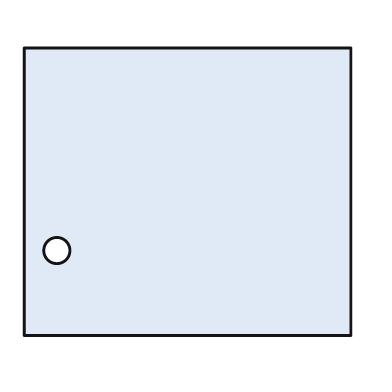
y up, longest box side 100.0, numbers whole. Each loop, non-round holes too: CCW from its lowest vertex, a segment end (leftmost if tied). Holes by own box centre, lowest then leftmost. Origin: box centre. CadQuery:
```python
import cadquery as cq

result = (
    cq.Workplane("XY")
    .moveTo(-50.0, -44.0)
    .lineTo(50.0, -44.0)
    .lineTo(50.0, 44.0)
    .lineTo(-50.0, 44.0)
    .close()
    .moveTo(-40.0, -18.0)
    .circle(4.0)
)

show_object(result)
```